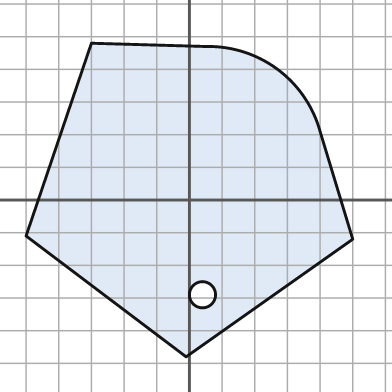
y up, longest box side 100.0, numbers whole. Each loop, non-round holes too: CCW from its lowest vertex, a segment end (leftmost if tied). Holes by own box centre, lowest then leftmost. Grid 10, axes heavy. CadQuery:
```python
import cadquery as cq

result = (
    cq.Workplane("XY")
    .moveTo(-1.0, -48.0)
    .lineTo(50.0, -12.0)
    .lineTo(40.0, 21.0)
    .threePointArc((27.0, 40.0), (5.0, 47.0))
    .lineTo(-30.0, 48.0)
    .lineTo(-50.0, -11.0)
    .close()
    .moveTo(4.0, -29.0)
    .circle(4.0)
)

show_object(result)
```